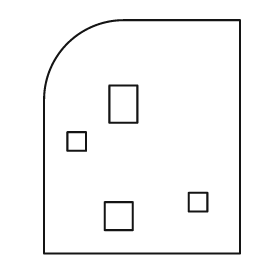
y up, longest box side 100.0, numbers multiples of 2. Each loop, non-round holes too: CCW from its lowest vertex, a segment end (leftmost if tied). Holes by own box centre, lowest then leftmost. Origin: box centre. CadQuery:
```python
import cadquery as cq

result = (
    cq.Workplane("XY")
    .moveTo(-42.0, -50.0)
    .lineTo(42.0, -50.0)
    .lineTo(42.0, 50.0)
    .lineTo(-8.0, 50.0)
    .threePointArc((-32.0, 40.0), (-42.0, 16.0))
    .close()
    .moveTo(-16.0, -40.0)
    .lineTo(-4.0, -40.0)
    .lineTo(-4.0, -28.0)
    .lineTo(-16.0, -28.0)
    .close()
    .moveTo(20.0, -32.0)
    .lineTo(28.0, -32.0)
    .lineTo(28.0, -24.0)
    .lineTo(20.0, -24.0)
    .close()
    .moveTo(-32.0, -6.0)
    .lineTo(-24.0, -6.0)
    .lineTo(-24.0, 2.0)
    .lineTo(-32.0, 2.0)
    .close()
    .moveTo(-14.0, 6.0)
    .lineTo(-2.0, 6.0)
    .lineTo(-2.0, 22.0)
    .lineTo(-14.0, 22.0)
    .close()
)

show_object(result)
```